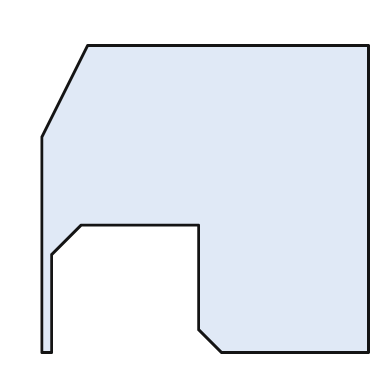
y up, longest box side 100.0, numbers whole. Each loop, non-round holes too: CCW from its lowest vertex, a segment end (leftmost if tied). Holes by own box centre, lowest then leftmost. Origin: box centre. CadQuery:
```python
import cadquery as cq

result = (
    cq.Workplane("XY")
    .moveTo(-50.0, -47.0)
    .lineTo(-47.0, -47.0)
    .lineTo(-47.0, -17.0)
    .lineTo(-38.0, -8.0)
    .lineTo(-2.0, -8.0)
    .lineTo(-2.0, -40.0)
    .lineTo(5.0, -47.0)
    .lineTo(50.0, -47.0)
    .lineTo(50.0, 47.0)
    .lineTo(-36.0, 47.0)
    .lineTo(-50.0, 19.0)
    .close()
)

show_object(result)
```